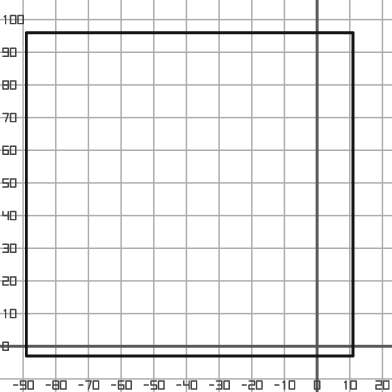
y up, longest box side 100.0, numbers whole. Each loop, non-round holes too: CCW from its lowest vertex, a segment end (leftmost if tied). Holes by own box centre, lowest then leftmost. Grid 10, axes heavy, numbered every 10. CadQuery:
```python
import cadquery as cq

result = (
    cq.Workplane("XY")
    .moveTo(-89.0, -3.0)
    .lineTo(11.0, -3.0)
    .lineTo(11.0, 96.0)
    .lineTo(-89.0, 96.0)
    .close()
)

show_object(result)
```